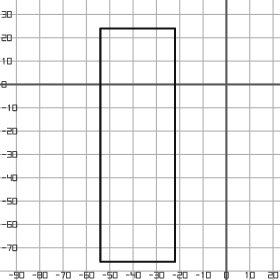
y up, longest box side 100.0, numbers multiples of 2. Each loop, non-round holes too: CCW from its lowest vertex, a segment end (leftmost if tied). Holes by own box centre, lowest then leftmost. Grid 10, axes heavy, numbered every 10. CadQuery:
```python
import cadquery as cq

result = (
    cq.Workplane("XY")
    .moveTo(-54.0, -76.0)
    .lineTo(-22.0, -76.0)
    .lineTo(-22.0, 24.0)
    .lineTo(-54.0, 24.0)
    .close()
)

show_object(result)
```